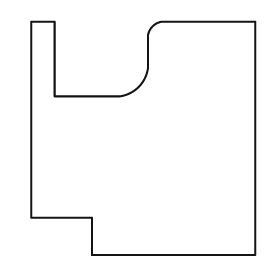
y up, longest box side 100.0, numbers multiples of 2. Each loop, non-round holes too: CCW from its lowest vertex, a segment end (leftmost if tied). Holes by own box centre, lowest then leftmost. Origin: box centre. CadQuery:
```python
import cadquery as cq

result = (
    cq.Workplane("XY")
    .moveTo(-22.0, -50.0)
    .lineTo(48.0, -50.0)
    .lineTo(48.0, 50.0)
    .lineTo(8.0, 50.0)
    .threePointArc((4.0, 48.0), (2.0, 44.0))
    .lineTo(2.0, 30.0)
    .threePointArc((-2.0, 22.0), (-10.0, 18.0))
    .lineTo(-38.0, 18.0)
    .lineTo(-38.0, 50.0)
    .lineTo(-48.0, 50.0)
    .lineTo(-48.0, -34.0)
    .lineTo(-22.0, -34.0)
    .close()
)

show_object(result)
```